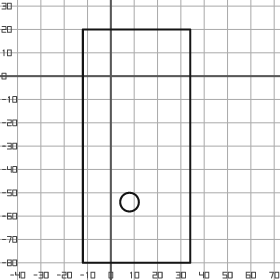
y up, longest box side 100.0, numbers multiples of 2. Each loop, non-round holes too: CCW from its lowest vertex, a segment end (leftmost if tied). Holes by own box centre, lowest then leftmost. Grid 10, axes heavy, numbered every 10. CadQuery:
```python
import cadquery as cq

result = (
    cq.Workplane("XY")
    .moveTo(-12.0, -80.0)
    .lineTo(34.0, -80.0)
    .lineTo(34.0, 20.0)
    .lineTo(-12.0, 20.0)
    .close()
    .moveTo(8.0, -54.0)
    .circle(4.0)
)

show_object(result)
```